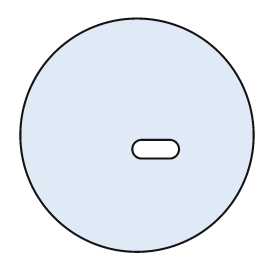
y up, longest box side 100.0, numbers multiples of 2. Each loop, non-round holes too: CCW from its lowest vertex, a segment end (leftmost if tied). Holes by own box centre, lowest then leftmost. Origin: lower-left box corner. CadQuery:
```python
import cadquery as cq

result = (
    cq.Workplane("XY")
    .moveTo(50.0, 50.0)
    .circle(50.0)
    .moveTo(52.0, 40.0)
    .lineTo(64.0, 40.0)
    .threePointArc((68.0, 44.0), (64.0, 48.0))
    .lineTo(52.0, 48.0)
    .threePointArc((48.0, 44.0), (52.0, 40.0))
    .close()
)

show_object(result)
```